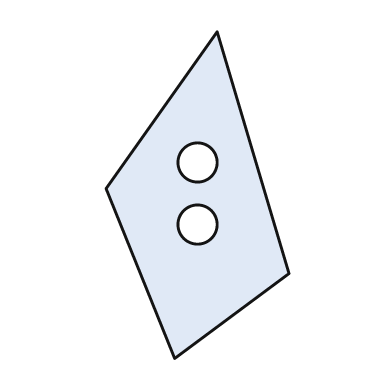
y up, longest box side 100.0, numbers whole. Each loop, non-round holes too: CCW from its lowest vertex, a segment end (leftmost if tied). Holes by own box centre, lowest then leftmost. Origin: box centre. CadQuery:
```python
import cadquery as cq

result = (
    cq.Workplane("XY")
    .moveTo(-7.0, -50.0)
    .lineTo(28.0, -24.0)
    .lineTo(6.0, 50.0)
    .lineTo(-28.0, 2.0)
    .close()
    .moveTo(0.0, -9.0)
    .circle(6.0)
    .moveTo(0.0, 10.0)
    .circle(6.0)
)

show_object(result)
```